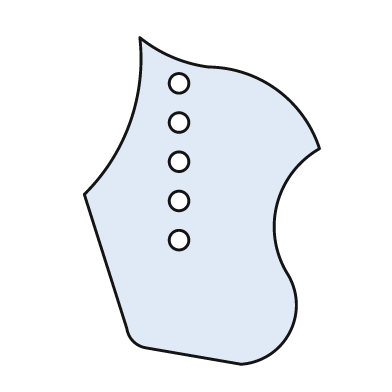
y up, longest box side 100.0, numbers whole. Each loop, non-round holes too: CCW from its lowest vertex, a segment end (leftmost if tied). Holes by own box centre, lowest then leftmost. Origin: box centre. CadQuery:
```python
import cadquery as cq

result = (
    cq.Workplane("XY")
    .moveTo(12.0, -50.0)
    .threePointArc((27.0, -40.0), (26.0, -22.0))
    .threePointArc((23.0, -1.0), (36.0, 16.0))
    .threePointArc((23.0, 34.0), (2.0, 41.0))
    .threePointArc((-9.0, 44.0), (-19.0, 50.0))
    .threePointArc((-22.0, 24.0), (-36.0, 2.0))
    .lineTo(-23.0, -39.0)
    .threePointArc((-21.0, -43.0), (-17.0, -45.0))
    .close()
    .moveTo(-7.0, -12.0)
    .circle(3.0)
    .moveTo(-7.0, 0.0)
    .circle(3.0)
    .moveTo(-7.0, 12.0)
    .circle(3.0)
    .moveTo(-7.0, 24.0)
    .circle(3.0)
    .moveTo(-7.0, 36.0)
    .circle(3.0)
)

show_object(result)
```